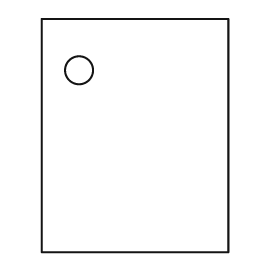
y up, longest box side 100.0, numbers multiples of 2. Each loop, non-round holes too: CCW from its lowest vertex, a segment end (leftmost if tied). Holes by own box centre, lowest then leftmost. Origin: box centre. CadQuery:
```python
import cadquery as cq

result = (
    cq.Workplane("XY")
    .moveTo(-40.0, -50.0)
    .lineTo(40.0, -50.0)
    .lineTo(40.0, 50.0)
    .lineTo(-40.0, 50.0)
    .close()
    .moveTo(-24.0, 28.0)
    .circle(6.0)
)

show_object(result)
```